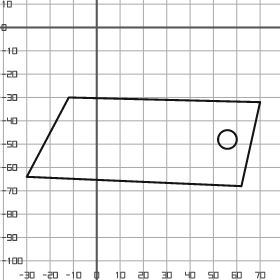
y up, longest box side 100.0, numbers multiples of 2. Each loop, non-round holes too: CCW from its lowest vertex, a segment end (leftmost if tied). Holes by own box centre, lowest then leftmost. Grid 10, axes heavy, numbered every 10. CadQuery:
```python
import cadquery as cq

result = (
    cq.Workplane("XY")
    .moveTo(62.0, -68.0)
    .lineTo(70.0, -32.0)
    .lineTo(-12.0, -30.0)
    .lineTo(-30.0, -64.0)
    .close()
    .moveTo(56.0, -48.0)
    .circle(4.0)
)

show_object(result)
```